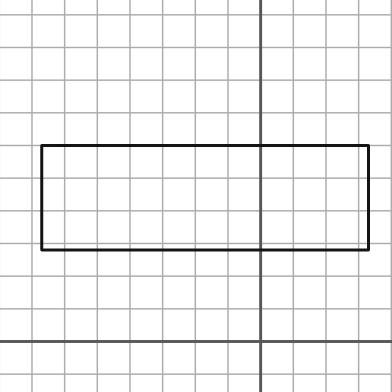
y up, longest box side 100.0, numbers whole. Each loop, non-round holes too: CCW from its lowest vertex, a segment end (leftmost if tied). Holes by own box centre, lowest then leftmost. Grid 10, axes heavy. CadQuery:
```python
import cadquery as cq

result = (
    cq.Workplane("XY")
    .moveTo(-67.0, 28.0)
    .lineTo(33.0, 28.0)
    .lineTo(33.0, 60.0)
    .lineTo(-67.0, 60.0)
    .close()
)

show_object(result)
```